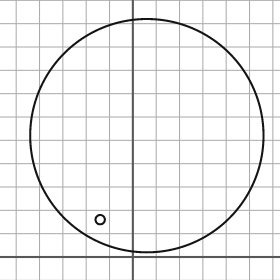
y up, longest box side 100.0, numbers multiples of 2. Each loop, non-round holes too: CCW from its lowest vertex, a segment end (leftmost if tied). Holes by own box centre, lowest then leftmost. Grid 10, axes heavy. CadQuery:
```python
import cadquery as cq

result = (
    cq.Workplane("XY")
    .moveTo(6.0, 52.0)
    .circle(50.0)
    .moveTo(-14.0, 16.0)
    .circle(2.0)
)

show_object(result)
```